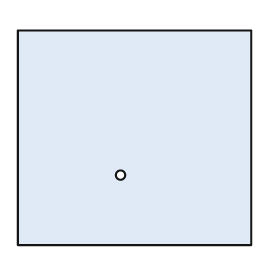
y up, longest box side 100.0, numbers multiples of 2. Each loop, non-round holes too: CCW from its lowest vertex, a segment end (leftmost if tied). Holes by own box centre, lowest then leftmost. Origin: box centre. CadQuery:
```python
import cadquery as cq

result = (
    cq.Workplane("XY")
    .moveTo(-50.0, -46.0)
    .lineTo(50.0, -46.0)
    .lineTo(50.0, 46.0)
    .lineTo(-50.0, 46.0)
    .close()
    .moveTo(-6.0, -16.0)
    .circle(2.0)
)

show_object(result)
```